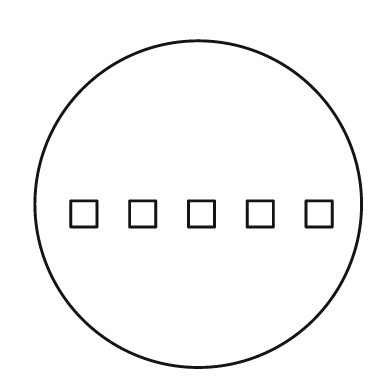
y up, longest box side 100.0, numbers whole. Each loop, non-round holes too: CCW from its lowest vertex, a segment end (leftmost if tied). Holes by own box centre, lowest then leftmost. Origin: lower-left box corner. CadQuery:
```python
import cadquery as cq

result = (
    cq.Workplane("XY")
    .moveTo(50.0, 50.0)
    .circle(50.0)
    .moveTo(11.0, 43.0)
    .lineTo(19.0, 43.0)
    .lineTo(19.0, 51.0)
    .lineTo(11.0, 51.0)
    .close()
    .moveTo(29.0, 43.0)
    .lineTo(37.0, 43.0)
    .lineTo(37.0, 51.0)
    .lineTo(29.0, 51.0)
    .close()
    .moveTo(47.0, 43.0)
    .lineTo(55.0, 43.0)
    .lineTo(55.0, 51.0)
    .lineTo(47.0, 51.0)
    .close()
    .moveTo(65.0, 43.0)
    .lineTo(73.0, 43.0)
    .lineTo(73.0, 51.0)
    .lineTo(65.0, 51.0)
    .close()
    .moveTo(83.0, 43.0)
    .lineTo(91.0, 43.0)
    .lineTo(91.0, 51.0)
    .lineTo(83.0, 51.0)
    .close()
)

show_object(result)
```